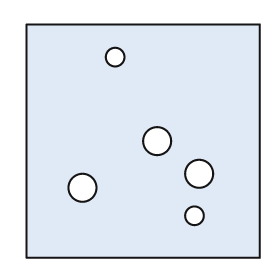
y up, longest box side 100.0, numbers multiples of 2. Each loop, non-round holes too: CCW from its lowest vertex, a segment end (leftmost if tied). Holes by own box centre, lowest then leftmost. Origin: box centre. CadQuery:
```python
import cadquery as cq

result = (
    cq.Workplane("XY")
    .moveTo(-50.0, -50.0)
    .lineTo(50.0, -50.0)
    .lineTo(50.0, 50.0)
    .lineTo(-50.0, 50.0)
    .close()
    .moveTo(22.0, -32.0)
    .circle(4.0)
    .moveTo(-26.0, -20.0)
    .circle(6.0)
    .moveTo(24.0, -14.0)
    .circle(6.0)
    .moveTo(6.0, 0.0)
    .circle(6.0)
    .moveTo(-12.0, 36.0)
    .circle(4.0)
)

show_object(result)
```